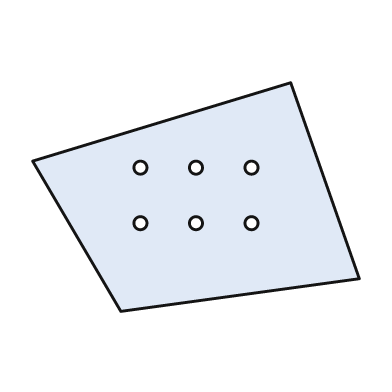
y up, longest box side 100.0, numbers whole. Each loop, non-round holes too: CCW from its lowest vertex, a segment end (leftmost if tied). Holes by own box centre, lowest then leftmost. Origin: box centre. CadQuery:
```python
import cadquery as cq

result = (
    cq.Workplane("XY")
    .moveTo(-23.0, -35.0)
    .lineTo(50.0, -25.0)
    .lineTo(29.0, 35.0)
    .lineTo(-50.0, 11.0)
    .close()
    .moveTo(-17.0, -8.0)
    .circle(2.0)
    .moveTo(0.0, -8.0)
    .circle(2.0)
    .moveTo(17.0, -8.0)
    .circle(2.0)
    .moveTo(-17.0, 9.0)
    .circle(2.0)
    .moveTo(0.0, 9.0)
    .circle(2.0)
    .moveTo(17.0, 9.0)
    .circle(2.0)
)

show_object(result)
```